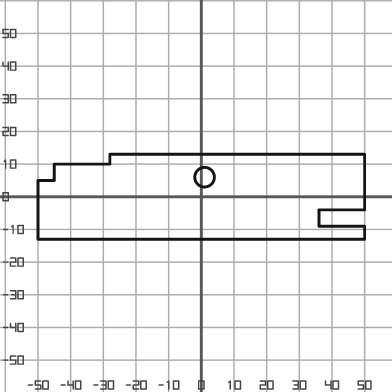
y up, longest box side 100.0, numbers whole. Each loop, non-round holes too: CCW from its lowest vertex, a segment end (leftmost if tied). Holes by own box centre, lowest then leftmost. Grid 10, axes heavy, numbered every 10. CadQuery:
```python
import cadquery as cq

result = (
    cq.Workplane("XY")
    .moveTo(-50.0, -13.0)
    .lineTo(50.0, -13.0)
    .lineTo(50.0, -9.0)
    .lineTo(36.0, -9.0)
    .lineTo(36.0, -4.0)
    .lineTo(50.0, -4.0)
    .lineTo(50.0, 13.0)
    .lineTo(-28.0, 13.0)
    .lineTo(-28.0, 10.0)
    .lineTo(-45.0, 10.0)
    .lineTo(-45.0, 5.0)
    .lineTo(-50.0, 5.0)
    .close()
    .moveTo(1.0, 6.0)
    .circle(3.0)
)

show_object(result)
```